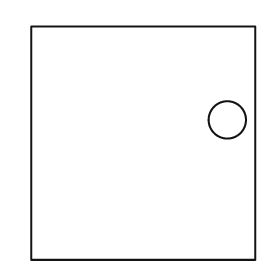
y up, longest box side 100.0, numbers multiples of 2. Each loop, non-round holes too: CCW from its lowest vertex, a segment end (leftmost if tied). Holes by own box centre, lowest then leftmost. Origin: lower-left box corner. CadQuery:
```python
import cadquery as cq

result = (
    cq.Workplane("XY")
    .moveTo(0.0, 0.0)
    .lineTo(96.0, 0.0)
    .lineTo(96.0, 100.0)
    .lineTo(0.0, 100.0)
    .close()
    .moveTo(84.0, 60.0)
    .circle(8.0)
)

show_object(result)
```